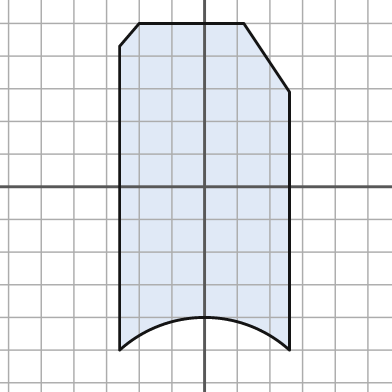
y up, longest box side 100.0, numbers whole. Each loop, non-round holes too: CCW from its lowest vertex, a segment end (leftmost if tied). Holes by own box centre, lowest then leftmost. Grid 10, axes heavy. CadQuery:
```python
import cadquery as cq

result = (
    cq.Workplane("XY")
    .moveTo(-26.0, -50.0)
    .threePointArc((0.0, -40.0), (26.0, -50.0))
    .lineTo(26.0, 29.0)
    .lineTo(12.0, 50.0)
    .lineTo(-20.0, 50.0)
    .lineTo(-26.0, 43.0)
    .close()
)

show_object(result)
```